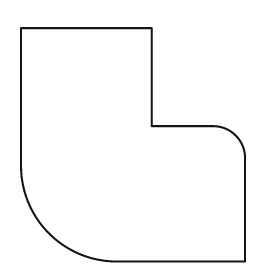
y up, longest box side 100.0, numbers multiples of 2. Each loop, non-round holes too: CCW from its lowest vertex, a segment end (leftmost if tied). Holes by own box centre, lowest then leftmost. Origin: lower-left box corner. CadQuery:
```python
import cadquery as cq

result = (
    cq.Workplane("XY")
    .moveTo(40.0, 0.0)
    .lineTo(96.0, 0.0)
    .lineTo(96.0, 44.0)
    .threePointArc((92.0, 54.0), (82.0, 58.0))
    .lineTo(56.0, 58.0)
    .lineTo(56.0, 100.0)
    .lineTo(0.0, 100.0)
    .lineTo(0.0, 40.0)
    .threePointArc((12.0, 12.0), (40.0, 0.0))
    .close()
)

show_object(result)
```